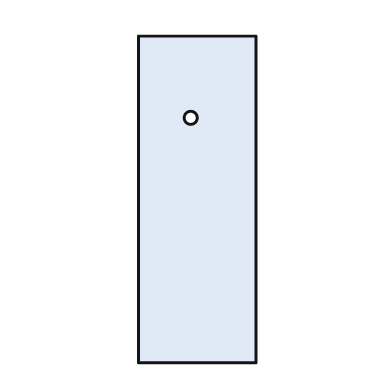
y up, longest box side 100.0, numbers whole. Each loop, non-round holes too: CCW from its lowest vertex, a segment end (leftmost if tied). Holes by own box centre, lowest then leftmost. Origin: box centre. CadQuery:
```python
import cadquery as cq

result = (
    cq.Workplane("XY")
    .moveTo(-18.0, -50.0)
    .lineTo(18.0, -50.0)
    .lineTo(18.0, 50.0)
    .lineTo(-18.0, 50.0)
    .close()
    .moveTo(-2.0, 25.0)
    .circle(2.0)
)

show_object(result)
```